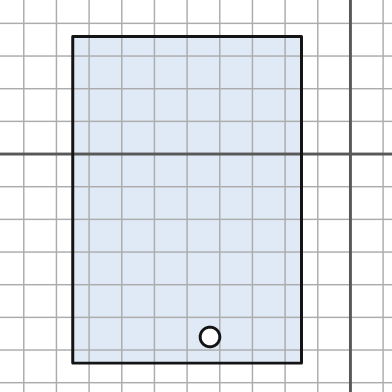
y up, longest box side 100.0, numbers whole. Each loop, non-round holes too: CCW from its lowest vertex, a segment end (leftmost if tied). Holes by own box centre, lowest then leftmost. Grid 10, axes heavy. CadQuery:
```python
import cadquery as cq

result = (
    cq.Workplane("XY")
    .moveTo(-85.0, -64.0)
    .lineTo(-15.0, -64.0)
    .lineTo(-15.0, 36.0)
    .lineTo(-85.0, 36.0)
    .close()
    .moveTo(-43.0, -56.0)
    .circle(3.0)
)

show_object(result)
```